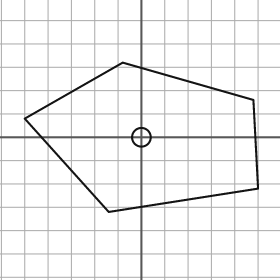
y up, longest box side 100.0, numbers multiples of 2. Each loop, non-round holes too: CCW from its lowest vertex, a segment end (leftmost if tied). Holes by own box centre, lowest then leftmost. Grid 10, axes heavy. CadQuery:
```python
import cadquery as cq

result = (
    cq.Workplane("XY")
    .moveTo(-14.0, -32.0)
    .lineTo(50.0, -22.0)
    .lineTo(48.0, 16.0)
    .lineTo(-8.0, 32.0)
    .lineTo(-50.0, 8.0)
    .close()
    .moveTo(0.0, 0.0)
    .circle(4.0)
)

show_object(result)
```